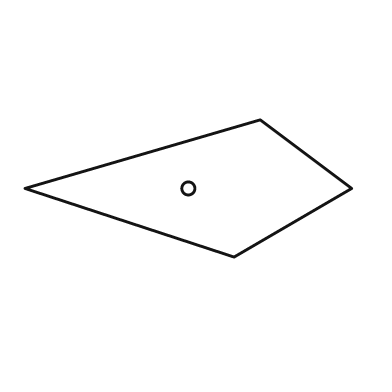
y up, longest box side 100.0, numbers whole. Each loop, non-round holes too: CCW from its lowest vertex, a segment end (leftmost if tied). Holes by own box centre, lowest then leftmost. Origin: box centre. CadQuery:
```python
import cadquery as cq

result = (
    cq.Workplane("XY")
    .moveTo(14.0, -21.0)
    .lineTo(50.0, 0.0)
    .lineTo(22.0, 21.0)
    .lineTo(-50.0, 0.0)
    .close()
    .moveTo(0.0, 0.0)
    .circle(2.0)
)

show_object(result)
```